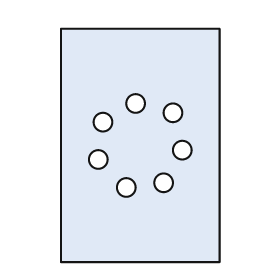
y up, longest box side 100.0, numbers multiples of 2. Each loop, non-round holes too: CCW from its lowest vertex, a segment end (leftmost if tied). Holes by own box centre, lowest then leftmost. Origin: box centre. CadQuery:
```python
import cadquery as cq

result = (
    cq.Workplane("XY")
    .moveTo(-34.0, -50.0)
    .lineTo(34.0, -50.0)
    .lineTo(34.0, 50.0)
    .lineTo(-34.0, 50.0)
    .close()
    .moveTo(-6.0, -18.0)
    .circle(4.0)
    .moveTo(10.0, -16.0)
    .circle(4.0)
    .moveTo(-18.0, -6.0)
    .circle(4.0)
    .moveTo(18.0, -2.0)
    .circle(4.0)
    .moveTo(-16.0, 10.0)
    .circle(4.0)
    .moveTo(14.0, 14.0)
    .circle(4.0)
    .moveTo(-2.0, 18.0)
    .circle(4.0)
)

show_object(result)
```